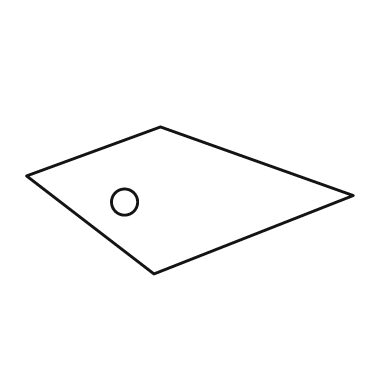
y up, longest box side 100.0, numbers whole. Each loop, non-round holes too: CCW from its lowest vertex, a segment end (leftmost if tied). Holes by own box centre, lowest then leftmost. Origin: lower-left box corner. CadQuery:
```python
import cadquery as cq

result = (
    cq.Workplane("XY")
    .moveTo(39.0, 0.0)
    .lineTo(100.0, 24.0)
    .lineTo(41.0, 45.0)
    .lineTo(0.0, 30.0)
    .close()
    .moveTo(30.0, 22.0)
    .circle(4.0)
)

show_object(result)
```